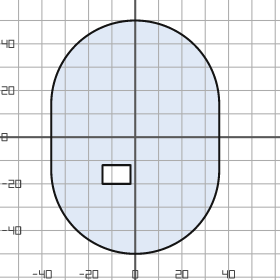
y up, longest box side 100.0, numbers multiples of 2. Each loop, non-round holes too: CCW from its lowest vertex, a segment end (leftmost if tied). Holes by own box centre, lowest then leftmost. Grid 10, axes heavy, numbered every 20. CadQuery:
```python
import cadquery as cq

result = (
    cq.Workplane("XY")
    .moveTo(-36.0, -14.0)
    .threePointArc((0.0, -50.0), (36.0, -14.0))
    .lineTo(36.0, 14.0)
    .threePointArc((0.0, 50.0), (-36.0, 14.0))
    .close()
    .moveTo(-14.0, -20.0)
    .lineTo(-2.0, -20.0)
    .lineTo(-2.0, -12.0)
    .lineTo(-14.0, -12.0)
    .close()
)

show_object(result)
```